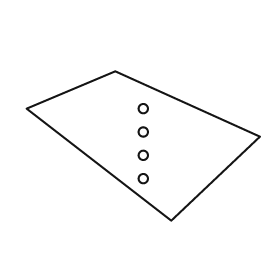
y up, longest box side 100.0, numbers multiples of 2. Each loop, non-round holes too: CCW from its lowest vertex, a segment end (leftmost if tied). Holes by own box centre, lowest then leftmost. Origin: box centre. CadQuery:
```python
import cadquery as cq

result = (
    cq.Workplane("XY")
    .moveTo(12.0, -32.0)
    .lineTo(50.0, 4.0)
    .lineTo(-12.0, 32.0)
    .lineTo(-50.0, 16.0)
    .close()
    .moveTo(0.0, -14.0)
    .circle(2.0)
    .moveTo(0.0, -4.0)
    .circle(2.0)
    .moveTo(0.0, 6.0)
    .circle(2.0)
    .moveTo(0.0, 16.0)
    .circle(2.0)
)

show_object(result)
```